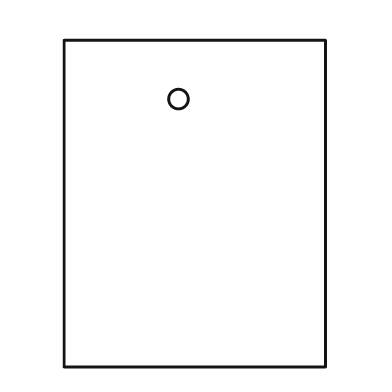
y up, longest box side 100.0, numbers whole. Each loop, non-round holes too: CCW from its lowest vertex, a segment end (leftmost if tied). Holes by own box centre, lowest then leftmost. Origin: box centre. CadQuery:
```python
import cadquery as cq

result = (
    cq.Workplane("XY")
    .moveTo(-40.0, -50.0)
    .lineTo(40.0, -50.0)
    .lineTo(40.0, 50.0)
    .lineTo(-40.0, 50.0)
    .close()
    .moveTo(-5.0, 32.0)
    .circle(3.0)
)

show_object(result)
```